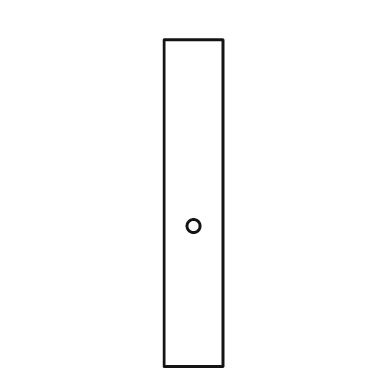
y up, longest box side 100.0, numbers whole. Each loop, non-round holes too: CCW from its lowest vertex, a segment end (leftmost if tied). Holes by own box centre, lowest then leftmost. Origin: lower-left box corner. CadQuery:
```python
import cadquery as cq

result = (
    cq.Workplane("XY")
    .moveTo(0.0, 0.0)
    .lineTo(18.0, 0.0)
    .lineTo(18.0, 100.0)
    .lineTo(0.0, 100.0)
    .close()
    .moveTo(9.0, 43.0)
    .circle(2.0)
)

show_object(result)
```